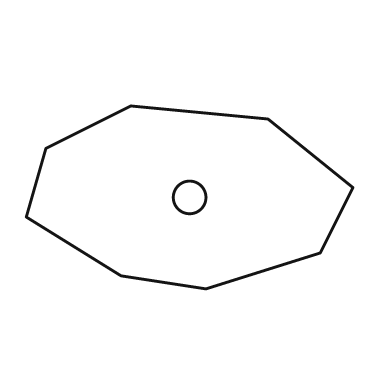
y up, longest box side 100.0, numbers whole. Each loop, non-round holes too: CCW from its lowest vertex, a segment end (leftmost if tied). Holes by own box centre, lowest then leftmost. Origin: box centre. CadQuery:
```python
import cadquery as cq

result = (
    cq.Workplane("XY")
    .moveTo(5.0, -28.0)
    .lineTo(40.0, -17.0)
    .lineTo(50.0, 3.0)
    .lineTo(24.0, 24.0)
    .lineTo(-18.0, 28.0)
    .lineTo(-44.0, 15.0)
    .lineTo(-50.0, -6.0)
    .lineTo(-21.0, -24.0)
    .close()
    .moveTo(0.0, 0.0)
    .circle(5.0)
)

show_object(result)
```